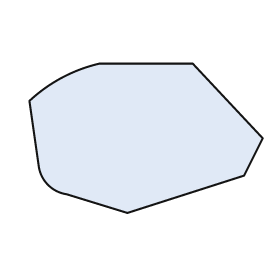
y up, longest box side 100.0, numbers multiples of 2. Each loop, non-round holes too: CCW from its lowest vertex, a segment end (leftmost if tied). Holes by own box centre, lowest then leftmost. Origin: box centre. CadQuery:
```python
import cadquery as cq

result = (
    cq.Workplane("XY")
    .moveTo(-8.0, -32.0)
    .lineTo(42.0, -16.0)
    .lineTo(50.0, 0.0)
    .lineTo(20.0, 32.0)
    .lineTo(-20.0, 32.0)
    .threePointArc((-36.0, 26.0), (-50.0, 16.0))
    .lineTo(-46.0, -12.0)
    .threePointArc((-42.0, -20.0), (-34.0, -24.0))
    .close()
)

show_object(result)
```